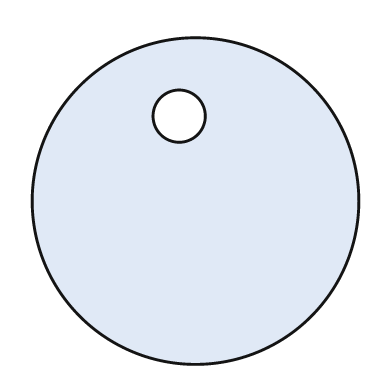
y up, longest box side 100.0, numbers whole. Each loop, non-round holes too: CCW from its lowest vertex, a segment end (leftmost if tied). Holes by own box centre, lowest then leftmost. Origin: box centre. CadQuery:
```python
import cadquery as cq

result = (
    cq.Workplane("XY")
    .moveTo(0.0, 0.0)
    .circle(50.0)
    .moveTo(-5.0, 26.0)
    .circle(8.0)
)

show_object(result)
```